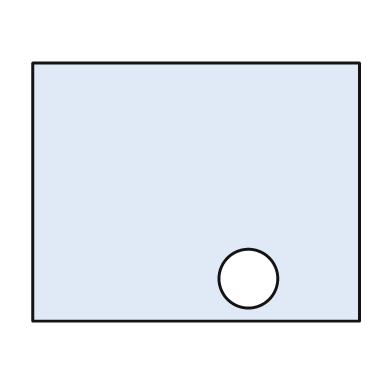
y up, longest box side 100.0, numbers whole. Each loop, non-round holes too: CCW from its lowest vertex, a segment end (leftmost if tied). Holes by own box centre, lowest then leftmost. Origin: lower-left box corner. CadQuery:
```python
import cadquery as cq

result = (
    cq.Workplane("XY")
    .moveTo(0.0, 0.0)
    .lineTo(100.0, 0.0)
    .lineTo(100.0, 79.0)
    .lineTo(0.0, 79.0)
    .close()
    .moveTo(66.0, 13.0)
    .circle(9.0)
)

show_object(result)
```